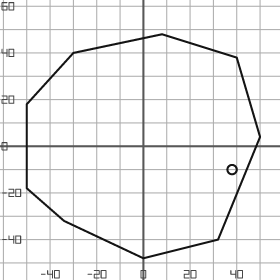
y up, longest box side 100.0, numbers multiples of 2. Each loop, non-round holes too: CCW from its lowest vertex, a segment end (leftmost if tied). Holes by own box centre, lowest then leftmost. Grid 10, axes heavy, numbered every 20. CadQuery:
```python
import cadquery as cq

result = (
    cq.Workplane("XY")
    .moveTo(0.0, -48.0)
    .lineTo(32.0, -40.0)
    .lineTo(50.0, 4.0)
    .lineTo(40.0, 38.0)
    .lineTo(8.0, 48.0)
    .lineTo(-30.0, 40.0)
    .lineTo(-50.0, 18.0)
    .lineTo(-50.0, -18.0)
    .lineTo(-34.0, -32.0)
    .close()
    .moveTo(38.0, -10.0)
    .circle(2.0)
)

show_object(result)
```